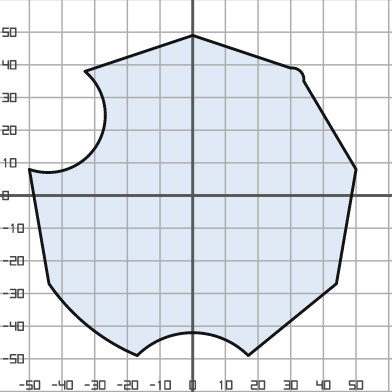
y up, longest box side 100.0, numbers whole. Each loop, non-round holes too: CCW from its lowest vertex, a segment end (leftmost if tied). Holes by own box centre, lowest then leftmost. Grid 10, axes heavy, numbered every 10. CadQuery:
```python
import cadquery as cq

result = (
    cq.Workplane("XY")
    .moveTo(-17.0, -49.0)
    .threePointArc((0.0, -42.0), (17.0, -49.0))
    .lineTo(44.0, -27.0)
    .lineTo(50.0, 8.0)
    .lineTo(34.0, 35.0)
    .threePointArc((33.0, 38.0), (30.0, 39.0))
    .lineTo(0.0, 49.0)
    .lineTo(-33.0, 38.0)
    .threePointArc((-29.0, 16.0), (-50.0, 8.0))
    .lineTo(-44.0, -27.0)
    .threePointArc((-32.0, -40.0), (-17.0, -49.0))
    .close()
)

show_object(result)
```